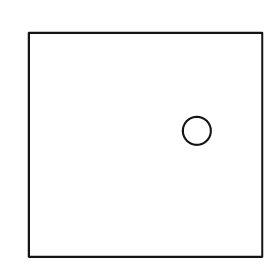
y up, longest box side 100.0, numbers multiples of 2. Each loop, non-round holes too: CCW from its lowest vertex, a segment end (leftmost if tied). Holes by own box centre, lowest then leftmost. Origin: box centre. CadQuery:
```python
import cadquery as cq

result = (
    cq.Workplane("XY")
    .moveTo(-50.0, -48.0)
    .lineTo(50.0, -48.0)
    .lineTo(50.0, 48.0)
    .lineTo(-50.0, 48.0)
    .close()
    .moveTo(22.0, 6.0)
    .circle(6.0)
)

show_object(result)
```